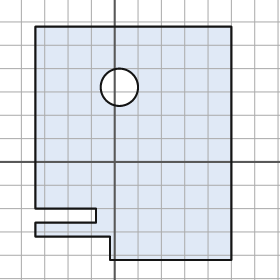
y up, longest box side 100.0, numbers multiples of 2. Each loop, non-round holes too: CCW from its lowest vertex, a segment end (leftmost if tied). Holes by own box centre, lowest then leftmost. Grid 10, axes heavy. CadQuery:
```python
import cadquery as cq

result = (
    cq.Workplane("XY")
    .moveTo(-2.0, -42.0)
    .lineTo(50.0, -42.0)
    .lineTo(50.0, 58.0)
    .lineTo(-34.0, 58.0)
    .lineTo(-34.0, -20.0)
    .lineTo(-8.0, -20.0)
    .lineTo(-8.0, -26.0)
    .lineTo(-34.0, -26.0)
    .lineTo(-34.0, -32.0)
    .lineTo(-2.0, -32.0)
    .close()
    .moveTo(2.0, 32.0)
    .circle(8.0)
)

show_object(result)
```